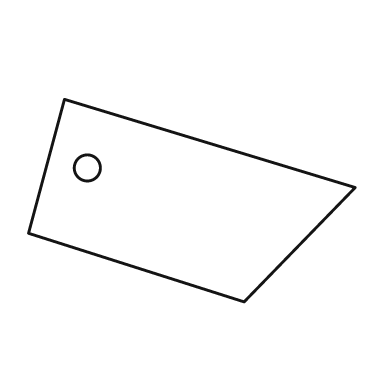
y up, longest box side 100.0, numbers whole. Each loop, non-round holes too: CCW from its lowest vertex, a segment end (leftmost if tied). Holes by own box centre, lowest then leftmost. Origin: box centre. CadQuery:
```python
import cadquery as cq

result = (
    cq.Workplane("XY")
    .moveTo(16.0, -31.0)
    .lineTo(50.0, 4.0)
    .lineTo(-39.0, 31.0)
    .lineTo(-50.0, -10.0)
    .close()
    .moveTo(-32.0, 10.0)
    .circle(4.0)
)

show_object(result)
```